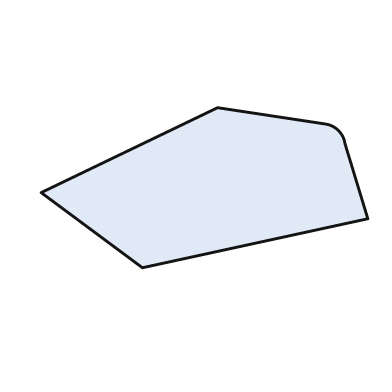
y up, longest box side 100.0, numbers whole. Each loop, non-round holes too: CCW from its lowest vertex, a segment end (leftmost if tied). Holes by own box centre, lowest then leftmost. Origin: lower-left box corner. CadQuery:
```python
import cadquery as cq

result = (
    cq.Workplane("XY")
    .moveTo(31.0, 0.0)
    .lineTo(100.0, 15.0)
    .lineTo(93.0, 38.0)
    .threePointArc((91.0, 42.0), (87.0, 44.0))
    .lineTo(54.0, 49.0)
    .lineTo(0.0, 23.0)
    .close()
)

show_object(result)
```